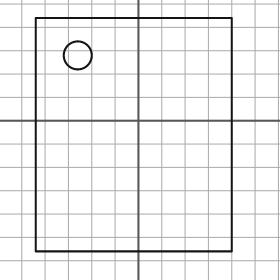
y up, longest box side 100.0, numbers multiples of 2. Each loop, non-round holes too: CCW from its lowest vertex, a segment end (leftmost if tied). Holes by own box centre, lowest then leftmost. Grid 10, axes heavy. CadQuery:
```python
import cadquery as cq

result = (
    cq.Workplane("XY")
    .moveTo(-44.0, -56.0)
    .lineTo(40.0, -56.0)
    .lineTo(40.0, 44.0)
    .lineTo(-44.0, 44.0)
    .close()
    .moveTo(-26.0, 28.0)
    .circle(6.0)
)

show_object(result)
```